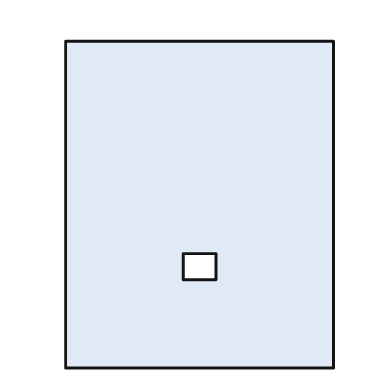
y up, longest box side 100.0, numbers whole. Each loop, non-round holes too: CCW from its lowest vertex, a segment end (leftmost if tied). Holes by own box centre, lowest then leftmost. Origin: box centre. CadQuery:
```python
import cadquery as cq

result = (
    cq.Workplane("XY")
    .moveTo(-41.0, -50.0)
    .lineTo(41.0, -50.0)
    .lineTo(41.0, 50.0)
    .lineTo(-41.0, 50.0)
    .close()
    .moveTo(-5.0, -23.0)
    .lineTo(5.0, -23.0)
    .lineTo(5.0, -15.0)
    .lineTo(-5.0, -15.0)
    .close()
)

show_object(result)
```